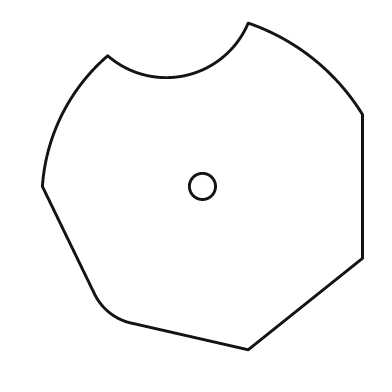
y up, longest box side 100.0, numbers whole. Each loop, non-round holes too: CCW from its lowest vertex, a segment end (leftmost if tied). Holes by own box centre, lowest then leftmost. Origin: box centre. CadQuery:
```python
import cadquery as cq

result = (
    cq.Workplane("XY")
    .moveTo(14.0, -50.0)
    .lineTo(49.0, -22.0)
    .lineTo(49.0, 22.0)
    .threePointArc((34.0, 39.0), (14.0, 50.0))
    .threePointArc((-5.0, 34.0), (-29.0, 40.0))
    .threePointArc((-43.0, 22.0), (-49.0, 0.0))
    .lineTo(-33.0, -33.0)
    .threePointArc((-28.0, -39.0), (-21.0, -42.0))
    .close()
    .moveTo(0.0, 0.0)
    .circle(4.0)
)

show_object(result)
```